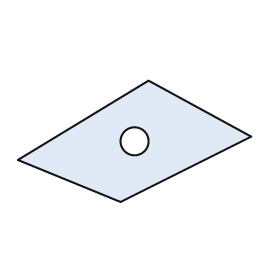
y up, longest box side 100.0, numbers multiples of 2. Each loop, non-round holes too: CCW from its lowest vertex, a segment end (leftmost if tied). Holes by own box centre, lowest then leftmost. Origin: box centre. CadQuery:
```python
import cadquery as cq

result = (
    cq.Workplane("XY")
    .moveTo(-6.0, -26.0)
    .lineTo(50.0, 2.0)
    .lineTo(6.0, 26.0)
    .lineTo(-50.0, -8.0)
    .close()
    .moveTo(0.0, 0.0)
    .circle(6.0)
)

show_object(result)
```